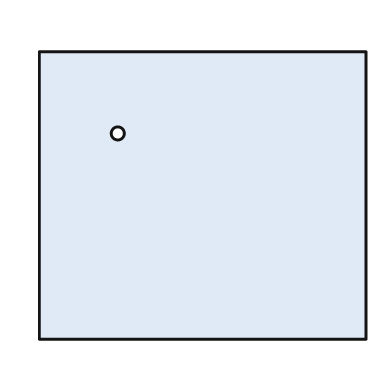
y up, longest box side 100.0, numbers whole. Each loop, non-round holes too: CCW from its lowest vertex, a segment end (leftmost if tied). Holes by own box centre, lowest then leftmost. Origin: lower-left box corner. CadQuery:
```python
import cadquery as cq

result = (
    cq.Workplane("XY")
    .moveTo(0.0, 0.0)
    .lineTo(100.0, 0.0)
    .lineTo(100.0, 88.0)
    .lineTo(0.0, 88.0)
    .close()
    .moveTo(24.0, 63.0)
    .circle(2.0)
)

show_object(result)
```